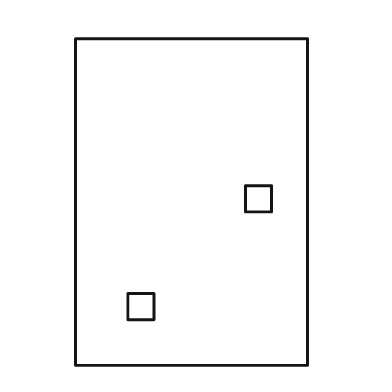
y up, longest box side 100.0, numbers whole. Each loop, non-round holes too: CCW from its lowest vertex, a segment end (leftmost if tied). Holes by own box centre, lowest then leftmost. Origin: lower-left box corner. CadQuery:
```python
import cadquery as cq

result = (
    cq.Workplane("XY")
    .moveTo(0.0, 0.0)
    .lineTo(71.0, 0.0)
    .lineTo(71.0, 100.0)
    .lineTo(0.0, 100.0)
    .close()
    .moveTo(16.0, 14.0)
    .lineTo(24.0, 14.0)
    .lineTo(24.0, 22.0)
    .lineTo(16.0, 22.0)
    .close()
    .moveTo(52.0, 47.0)
    .lineTo(60.0, 47.0)
    .lineTo(60.0, 55.0)
    .lineTo(52.0, 55.0)
    .close()
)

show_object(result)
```